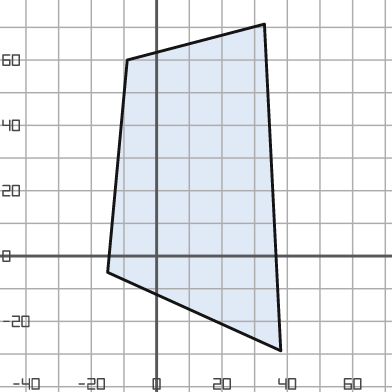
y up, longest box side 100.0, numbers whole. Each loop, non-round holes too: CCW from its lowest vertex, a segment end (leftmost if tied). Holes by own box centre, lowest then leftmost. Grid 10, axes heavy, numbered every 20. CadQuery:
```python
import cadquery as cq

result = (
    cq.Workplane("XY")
    .moveTo(38.0, -29.0)
    .lineTo(33.0, 71.0)
    .lineTo(-9.0, 60.0)
    .lineTo(-15.0, -5.0)
    .close()
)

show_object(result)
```